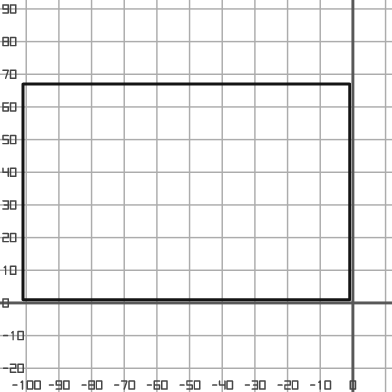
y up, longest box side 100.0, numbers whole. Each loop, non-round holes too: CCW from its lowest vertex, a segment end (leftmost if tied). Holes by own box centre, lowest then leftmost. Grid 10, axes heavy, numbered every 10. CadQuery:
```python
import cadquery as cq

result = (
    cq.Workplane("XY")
    .moveTo(-101.0, 1.0)
    .lineTo(-1.0, 1.0)
    .lineTo(-1.0, 67.0)
    .lineTo(-101.0, 67.0)
    .close()
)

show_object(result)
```